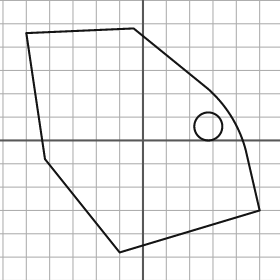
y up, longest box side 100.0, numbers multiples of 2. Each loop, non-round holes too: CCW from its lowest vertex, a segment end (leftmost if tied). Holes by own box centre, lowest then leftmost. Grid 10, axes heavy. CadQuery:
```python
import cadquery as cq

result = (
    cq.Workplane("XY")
    .moveTo(-10.0, -48.0)
    .lineTo(50.0, -30.0)
    .lineTo(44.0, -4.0)
    .threePointArc((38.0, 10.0), (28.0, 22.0))
    .lineTo(-4.0, 48.0)
    .lineTo(-50.0, 46.0)
    .lineTo(-42.0, -8.0)
    .close()
    .moveTo(28.0, 6.0)
    .circle(6.0)
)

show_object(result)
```